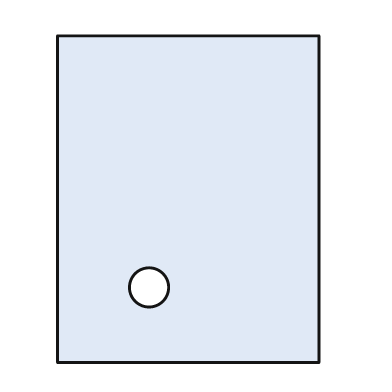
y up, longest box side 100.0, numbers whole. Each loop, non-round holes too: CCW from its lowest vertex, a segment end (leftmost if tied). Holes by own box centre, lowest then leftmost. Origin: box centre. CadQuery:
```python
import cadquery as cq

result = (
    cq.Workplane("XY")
    .moveTo(-40.0, -50.0)
    .lineTo(40.0, -50.0)
    .lineTo(40.0, 50.0)
    .lineTo(-40.0, 50.0)
    .close()
    .moveTo(-12.0, -27.0)
    .circle(6.0)
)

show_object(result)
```